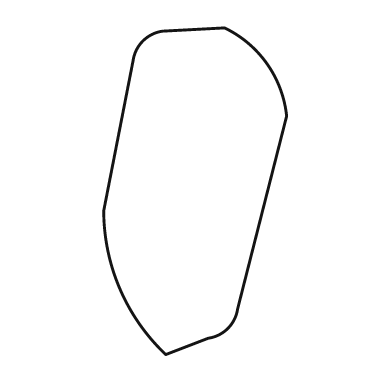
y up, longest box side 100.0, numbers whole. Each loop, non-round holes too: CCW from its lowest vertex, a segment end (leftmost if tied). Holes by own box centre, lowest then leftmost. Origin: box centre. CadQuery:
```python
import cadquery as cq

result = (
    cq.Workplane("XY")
    .moveTo(-9.0, -50.0)
    .lineTo(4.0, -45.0)
    .threePointArc((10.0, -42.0), (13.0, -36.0))
    .lineTo(28.0, 23.0)
    .threePointArc((22.0, 39.0), (9.0, 50.0))
    .lineTo(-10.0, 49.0)
    .threePointArc((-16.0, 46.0), (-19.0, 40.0))
    .lineTo(-28.0, -6.0)
    .threePointArc((-23.0, -30.0), (-9.0, -50.0))
    .close()
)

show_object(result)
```